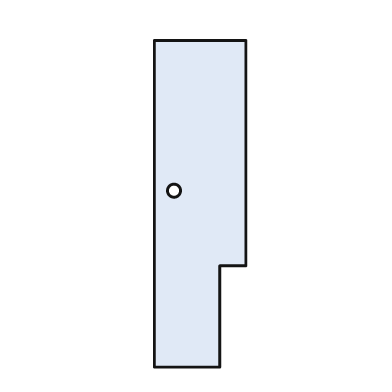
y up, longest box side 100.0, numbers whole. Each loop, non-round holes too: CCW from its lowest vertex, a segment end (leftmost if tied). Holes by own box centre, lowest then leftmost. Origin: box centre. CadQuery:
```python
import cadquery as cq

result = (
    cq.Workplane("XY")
    .moveTo(-14.0, -50.0)
    .lineTo(6.0, -50.0)
    .lineTo(6.0, -19.0)
    .lineTo(14.0, -19.0)
    .lineTo(14.0, 50.0)
    .lineTo(-14.0, 50.0)
    .close()
    .moveTo(-8.0, 4.0)
    .circle(2.0)
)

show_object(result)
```